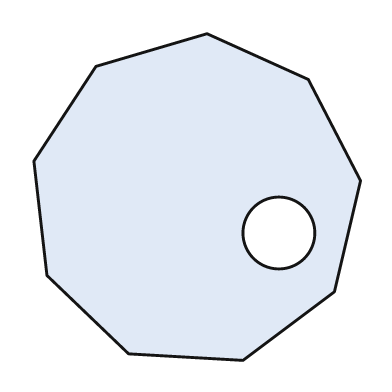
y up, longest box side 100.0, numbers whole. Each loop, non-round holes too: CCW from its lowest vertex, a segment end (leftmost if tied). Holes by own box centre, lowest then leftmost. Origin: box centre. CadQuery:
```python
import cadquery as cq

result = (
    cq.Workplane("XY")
    .moveTo(14.0, -50.0)
    .lineTo(42.0, -29.0)
    .lineTo(50.0, 5.0)
    .lineTo(34.0, 36.0)
    .lineTo(3.0, 50.0)
    .lineTo(-31.0, 40.0)
    .lineTo(-50.0, 11.0)
    .lineTo(-46.0, -24.0)
    .lineTo(-21.0, -48.0)
    .close()
    .moveTo(25.0, -11.0)
    .circle(11.0)
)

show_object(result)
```